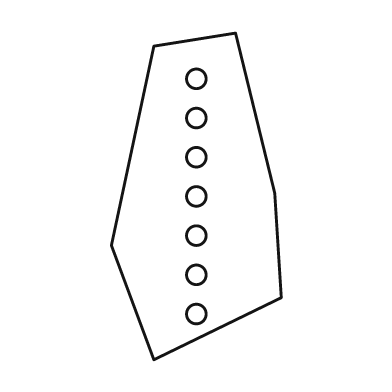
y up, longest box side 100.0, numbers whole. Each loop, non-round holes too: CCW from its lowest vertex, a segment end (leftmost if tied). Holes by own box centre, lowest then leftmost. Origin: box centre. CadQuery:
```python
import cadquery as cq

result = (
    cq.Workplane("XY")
    .moveTo(-13.0, -50.0)
    .lineTo(26.0, -31.0)
    .lineTo(24.0, 1.0)
    .lineTo(12.0, 50.0)
    .lineTo(-13.0, 46.0)
    .lineTo(-26.0, -15.0)
    .close()
    .moveTo(0.0, -36.0)
    .circle(3.0)
    .moveTo(0.0, -24.0)
    .circle(3.0)
    .moveTo(0.0, -12.0)
    .circle(3.0)
    .moveTo(0.0, 0.0)
    .circle(3.0)
    .moveTo(0.0, 12.0)
    .circle(3.0)
    .moveTo(0.0, 24.0)
    .circle(3.0)
    .moveTo(0.0, 36.0)
    .circle(3.0)
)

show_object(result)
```